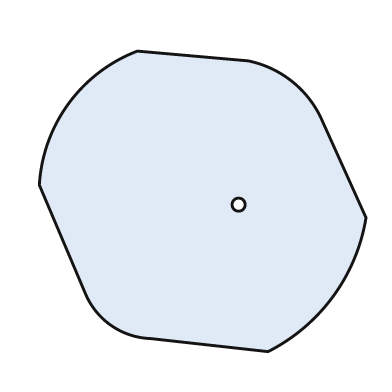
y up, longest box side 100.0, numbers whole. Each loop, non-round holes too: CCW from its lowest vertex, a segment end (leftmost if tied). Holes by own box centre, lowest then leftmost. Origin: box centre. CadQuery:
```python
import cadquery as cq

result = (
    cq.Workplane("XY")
    .moveTo(20.0, -46.0)
    .threePointArc((40.0, -29.0), (50.0, -5.0))
    .lineTo(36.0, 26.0)
    .threePointArc((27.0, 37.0), (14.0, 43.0))
    .lineTo(-20.0, 46.0)
    .threePointArc((-41.0, 30.0), (-50.0, 5.0))
    .lineTo(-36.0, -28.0)
    .threePointArc((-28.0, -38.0), (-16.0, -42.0))
    .close()
    .moveTo(11.0, -1.0)
    .circle(2.0)
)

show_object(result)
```